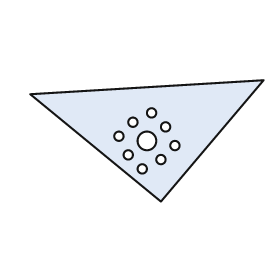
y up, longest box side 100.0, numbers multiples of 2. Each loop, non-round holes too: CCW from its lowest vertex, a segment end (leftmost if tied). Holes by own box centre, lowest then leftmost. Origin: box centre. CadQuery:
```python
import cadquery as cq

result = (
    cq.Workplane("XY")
    .moveTo(6.0, -26.0)
    .lineTo(50.0, 26.0)
    .lineTo(-50.0, 20.0)
    .close()
    .moveTo(-2.0, -12.0)
    .circle(2.0)
    .moveTo(6.0, -8.0)
    .circle(2.0)
    .moveTo(-8.0, -6.0)
    .circle(2.0)
    .moveTo(12.0, -2.0)
    .circle(2.0)
    .moveTo(0.0, 0.0)
    .circle(4.0)
    .moveTo(-12.0, 2.0)
    .circle(2.0)
    .moveTo(8.0, 6.0)
    .circle(2.0)
    .moveTo(-6.0, 8.0)
    .circle(2.0)
    .moveTo(2.0, 12.0)
    .circle(2.0)
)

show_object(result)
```